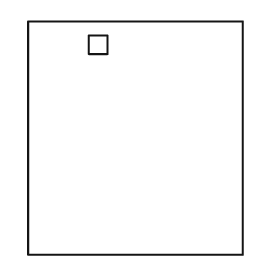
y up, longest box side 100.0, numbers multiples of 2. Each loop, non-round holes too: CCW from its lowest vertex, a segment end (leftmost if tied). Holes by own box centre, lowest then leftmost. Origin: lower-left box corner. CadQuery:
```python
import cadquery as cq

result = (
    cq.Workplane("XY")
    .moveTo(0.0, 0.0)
    .lineTo(92.0, 0.0)
    .lineTo(92.0, 100.0)
    .lineTo(0.0, 100.0)
    .close()
    .moveTo(26.0, 86.0)
    .lineTo(34.0, 86.0)
    .lineTo(34.0, 94.0)
    .lineTo(26.0, 94.0)
    .close()
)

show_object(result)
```